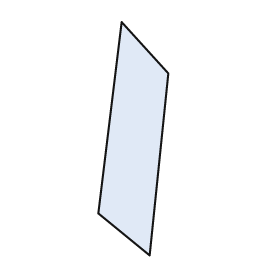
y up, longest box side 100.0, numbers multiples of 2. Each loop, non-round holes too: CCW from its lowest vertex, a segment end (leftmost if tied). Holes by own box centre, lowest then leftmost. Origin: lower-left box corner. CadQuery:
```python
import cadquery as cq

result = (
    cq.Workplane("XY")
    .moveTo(22.0, 0.0)
    .lineTo(30.0, 78.0)
    .lineTo(10.0, 100.0)
    .lineTo(0.0, 18.0)
    .close()
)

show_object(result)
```